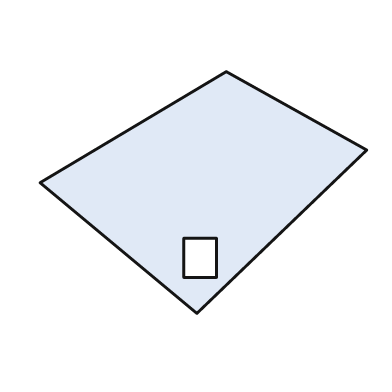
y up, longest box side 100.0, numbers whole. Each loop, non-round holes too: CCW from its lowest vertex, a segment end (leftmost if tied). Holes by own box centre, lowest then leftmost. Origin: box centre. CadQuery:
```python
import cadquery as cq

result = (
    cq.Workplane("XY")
    .moveTo(-2.0, -37.0)
    .lineTo(50.0, 13.0)
    .lineTo(7.0, 37.0)
    .lineTo(-50.0, 3.0)
    .close()
    .moveTo(-6.0, -26.0)
    .lineTo(4.0, -26.0)
    .lineTo(4.0, -14.0)
    .lineTo(-6.0, -14.0)
    .close()
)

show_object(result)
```